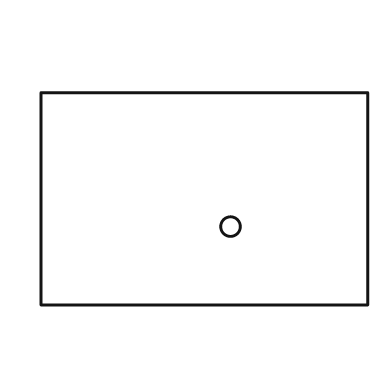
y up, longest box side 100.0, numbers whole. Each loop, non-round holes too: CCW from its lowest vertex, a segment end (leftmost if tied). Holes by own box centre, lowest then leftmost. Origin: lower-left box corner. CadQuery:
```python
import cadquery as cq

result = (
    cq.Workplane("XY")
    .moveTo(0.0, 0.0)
    .lineTo(100.0, 0.0)
    .lineTo(100.0, 65.0)
    .lineTo(0.0, 65.0)
    .close()
    .moveTo(58.0, 24.0)
    .circle(3.0)
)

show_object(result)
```